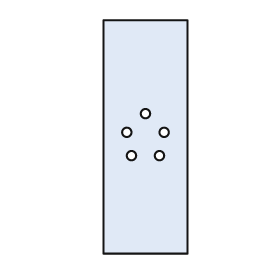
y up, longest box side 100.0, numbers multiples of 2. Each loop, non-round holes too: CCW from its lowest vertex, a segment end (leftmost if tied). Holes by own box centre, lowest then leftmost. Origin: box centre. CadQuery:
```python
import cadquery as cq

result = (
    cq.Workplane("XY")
    .moveTo(-18.0, -50.0)
    .lineTo(18.0, -50.0)
    .lineTo(18.0, 50.0)
    .lineTo(-18.0, 50.0)
    .close()
    .moveTo(-6.0, -8.0)
    .circle(2.0)
    .moveTo(6.0, -8.0)
    .circle(2.0)
    .moveTo(-8.0, 2.0)
    .circle(2.0)
    .moveTo(8.0, 2.0)
    .circle(2.0)
    .moveTo(0.0, 10.0)
    .circle(2.0)
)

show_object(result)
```